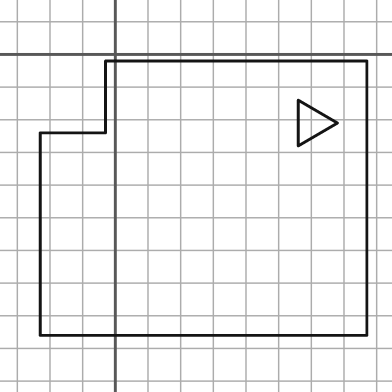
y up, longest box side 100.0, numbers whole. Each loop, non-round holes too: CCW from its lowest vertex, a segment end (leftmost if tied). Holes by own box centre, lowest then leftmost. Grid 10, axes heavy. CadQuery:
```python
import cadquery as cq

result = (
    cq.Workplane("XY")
    .moveTo(-23.0, -86.0)
    .lineTo(77.0, -86.0)
    .lineTo(77.0, -2.0)
    .lineTo(-3.0, -2.0)
    .lineTo(-3.0, -24.0)
    .lineTo(-23.0, -24.0)
    .close()
    .moveTo(56.0, -28.0)
    .lineTo(68.0, -21.0)
    .lineTo(56.0, -14.0)
    .close()
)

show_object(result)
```